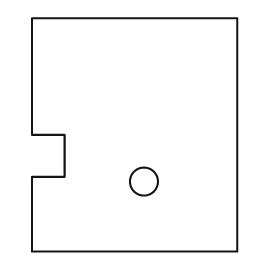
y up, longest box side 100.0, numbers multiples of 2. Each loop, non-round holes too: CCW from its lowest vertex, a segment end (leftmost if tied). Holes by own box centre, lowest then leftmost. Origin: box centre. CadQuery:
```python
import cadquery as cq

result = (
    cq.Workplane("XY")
    .moveTo(-44.0, -50.0)
    .lineTo(44.0, -50.0)
    .lineTo(44.0, 50.0)
    .lineTo(-44.0, 50.0)
    .lineTo(-44.0, 0.0)
    .lineTo(-30.0, 0.0)
    .lineTo(-30.0, -18.0)
    .lineTo(-44.0, -18.0)
    .close()
    .moveTo(4.0, -20.0)
    .circle(6.0)
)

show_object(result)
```